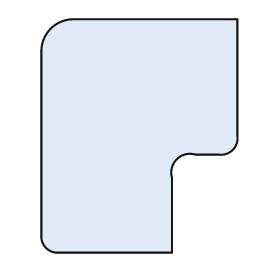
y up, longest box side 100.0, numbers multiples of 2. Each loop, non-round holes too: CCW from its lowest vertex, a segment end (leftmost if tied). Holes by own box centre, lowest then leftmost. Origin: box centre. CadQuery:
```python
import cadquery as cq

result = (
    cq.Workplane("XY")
    .moveTo(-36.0, -50.0)
    .lineTo(14.0, -50.0)
    .lineTo(14.0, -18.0)
    .threePointArc((16.0, -10.0), (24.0, -8.0))
    .lineTo(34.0, -8.0)
    .threePointArc((40.0, -6.0), (42.0, 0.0))
    .lineTo(42.0, 50.0)
    .lineTo(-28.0, 50.0)
    .threePointArc((-38.0, 46.0), (-42.0, 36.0))
    .lineTo(-42.0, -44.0)
    .threePointArc((-40.0, -48.0), (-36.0, -50.0))
    .close()
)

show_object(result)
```